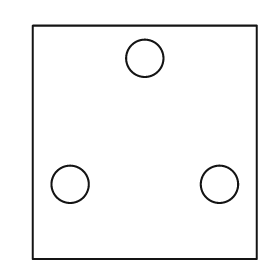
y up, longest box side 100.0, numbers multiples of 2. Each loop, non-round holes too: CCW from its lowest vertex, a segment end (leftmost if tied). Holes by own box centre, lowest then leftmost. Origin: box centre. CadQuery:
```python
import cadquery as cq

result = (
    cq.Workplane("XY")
    .moveTo(-48.0, -50.0)
    .lineTo(48.0, -50.0)
    .lineTo(48.0, 50.0)
    .lineTo(-48.0, 50.0)
    .close()
    .moveTo(-32.0, -18.0)
    .circle(8.0)
    .moveTo(32.0, -18.0)
    .circle(8.0)
    .moveTo(0.0, 36.0)
    .circle(8.0)
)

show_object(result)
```